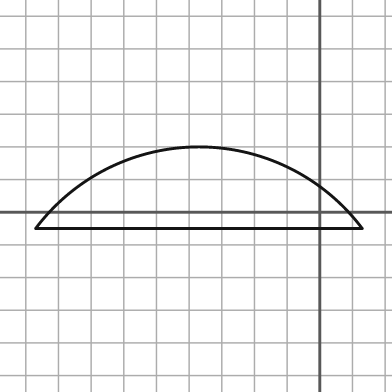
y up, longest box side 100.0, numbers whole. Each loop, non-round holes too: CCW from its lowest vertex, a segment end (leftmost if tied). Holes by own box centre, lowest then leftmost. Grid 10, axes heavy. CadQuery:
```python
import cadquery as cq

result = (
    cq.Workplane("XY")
    .moveTo(-87.0, -5.0)
    .lineTo(13.0, -5.0)
    .threePointArc((-37.0, 20.0), (-87.0, -5.0))
    .close()
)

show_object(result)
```